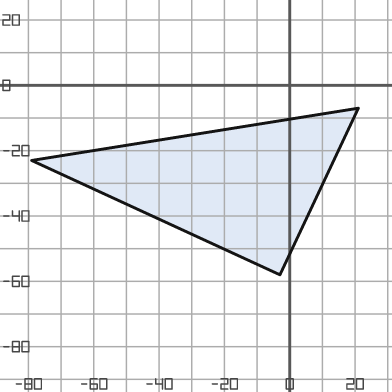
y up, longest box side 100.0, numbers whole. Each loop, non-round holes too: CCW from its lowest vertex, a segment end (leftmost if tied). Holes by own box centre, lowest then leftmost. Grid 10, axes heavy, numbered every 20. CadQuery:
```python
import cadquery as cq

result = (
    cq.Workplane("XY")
    .moveTo(-3.0, -58.0)
    .lineTo(21.0, -7.0)
    .lineTo(-79.0, -23.0)
    .close()
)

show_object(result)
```